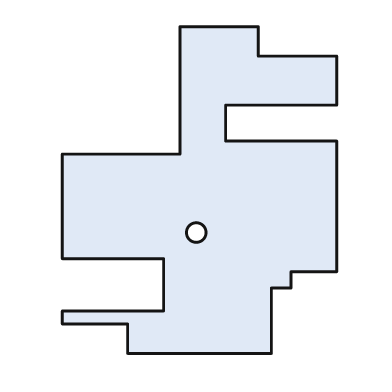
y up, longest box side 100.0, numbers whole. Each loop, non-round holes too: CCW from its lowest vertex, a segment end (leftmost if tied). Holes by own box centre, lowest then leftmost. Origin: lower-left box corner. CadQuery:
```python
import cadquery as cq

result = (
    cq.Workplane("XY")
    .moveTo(20.0, 0.0)
    .lineTo(64.0, 0.0)
    .lineTo(64.0, 20.0)
    .lineTo(70.0, 20.0)
    .lineTo(70.0, 25.0)
    .lineTo(84.0, 25.0)
    .lineTo(84.0, 65.0)
    .lineTo(50.0, 65.0)
    .lineTo(50.0, 76.0)
    .lineTo(84.0, 76.0)
    .lineTo(84.0, 91.0)
    .lineTo(60.0, 91.0)
    .lineTo(60.0, 100.0)
    .lineTo(36.0, 100.0)
    .lineTo(36.0, 61.0)
    .lineTo(0.0, 61.0)
    .lineTo(0.0, 29.0)
    .lineTo(31.0, 29.0)
    .lineTo(31.0, 13.0)
    .lineTo(0.0, 13.0)
    .lineTo(0.0, 9.0)
    .lineTo(20.0, 9.0)
    .close()
    .moveTo(41.0, 37.0)
    .circle(3.0)
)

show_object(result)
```